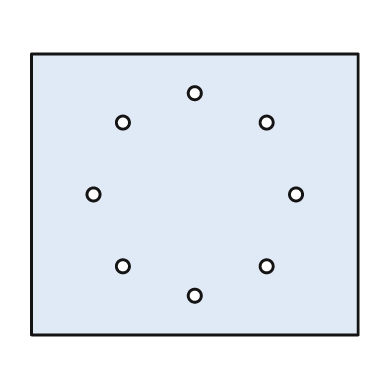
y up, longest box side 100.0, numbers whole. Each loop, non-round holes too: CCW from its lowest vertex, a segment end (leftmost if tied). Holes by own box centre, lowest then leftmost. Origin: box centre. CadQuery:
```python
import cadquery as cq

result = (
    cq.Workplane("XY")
    .moveTo(-50.0, -43.0)
    .lineTo(50.0, -43.0)
    .lineTo(50.0, 43.0)
    .lineTo(-50.0, 43.0)
    .close()
    .moveTo(0.0, -31.0)
    .circle(2.0)
    .moveTo(-22.0, -22.0)
    .circle(2.0)
    .moveTo(22.0, -22.0)
    .circle(2.0)
    .moveTo(-31.0, 0.0)
    .circle(2.0)
    .moveTo(31.0, 0.0)
    .circle(2.0)
    .moveTo(-22.0, 22.0)
    .circle(2.0)
    .moveTo(22.0, 22.0)
    .circle(2.0)
    .moveTo(0.0, 31.0)
    .circle(2.0)
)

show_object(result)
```